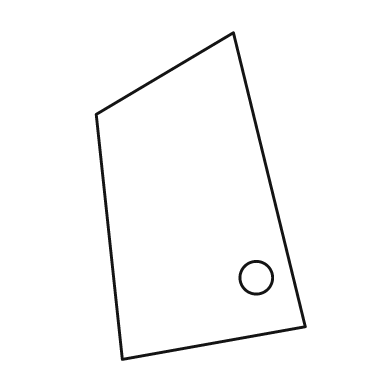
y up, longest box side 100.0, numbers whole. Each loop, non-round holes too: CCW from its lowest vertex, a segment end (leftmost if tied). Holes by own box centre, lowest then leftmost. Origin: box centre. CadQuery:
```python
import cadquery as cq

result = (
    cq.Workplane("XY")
    .moveTo(-24.0, -50.0)
    .lineTo(32.0, -40.0)
    .lineTo(10.0, 50.0)
    .lineTo(-32.0, 25.0)
    .close()
    .moveTo(17.0, -25.0)
    .circle(5.0)
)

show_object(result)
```